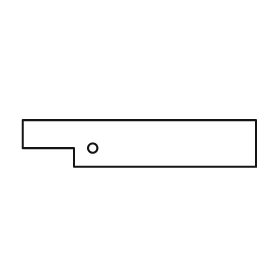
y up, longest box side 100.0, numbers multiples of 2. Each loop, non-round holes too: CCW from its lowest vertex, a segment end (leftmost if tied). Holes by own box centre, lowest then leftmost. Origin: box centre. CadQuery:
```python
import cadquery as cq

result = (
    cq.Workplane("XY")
    .moveTo(-28.0, -10.0)
    .lineTo(50.0, -10.0)
    .lineTo(50.0, 10.0)
    .lineTo(-50.0, 10.0)
    .lineTo(-50.0, -2.0)
    .lineTo(-28.0, -2.0)
    .close()
    .moveTo(-20.0, -2.0)
    .circle(2.0)
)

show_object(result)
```